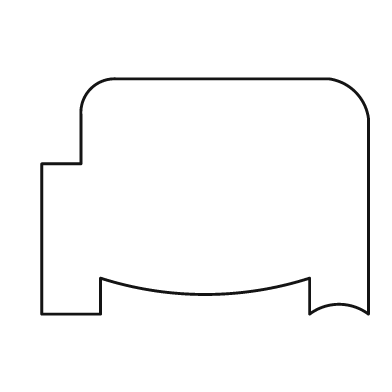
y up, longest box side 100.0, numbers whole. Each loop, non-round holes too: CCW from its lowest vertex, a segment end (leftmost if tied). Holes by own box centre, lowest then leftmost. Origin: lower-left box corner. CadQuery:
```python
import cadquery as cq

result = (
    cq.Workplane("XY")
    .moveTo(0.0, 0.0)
    .lineTo(18.0, 0.0)
    .lineTo(18.0, 11.0)
    .threePointArc((50.0, 6.0), (82.0, 11.0))
    .lineTo(82.0, 0.0)
    .threePointArc((91.0, 3.0), (100.0, 0.0))
    .lineTo(100.0, 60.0)
    .threePointArc((96.0, 68.0), (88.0, 72.0))
    .lineTo(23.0, 72.0)
    .threePointArc((15.0, 69.0), (12.0, 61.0))
    .lineTo(12.0, 46.0)
    .lineTo(0.0, 46.0)
    .close()
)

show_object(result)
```